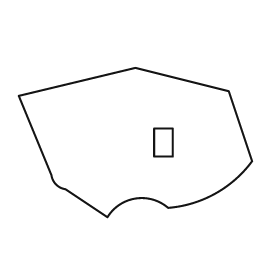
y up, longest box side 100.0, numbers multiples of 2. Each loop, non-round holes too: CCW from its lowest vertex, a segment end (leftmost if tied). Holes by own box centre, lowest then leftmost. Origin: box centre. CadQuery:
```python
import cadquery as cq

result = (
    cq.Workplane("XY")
    .moveTo(-12.0, -32.0)
    .threePointArc((0.0, -24.0), (14.0, -28.0))
    .threePointArc((34.0, -22.0), (50.0, -8.0))
    .lineTo(40.0, 22.0)
    .lineTo(0.0, 32.0)
    .lineTo(-50.0, 20.0)
    .lineTo(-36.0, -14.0)
    .threePointArc((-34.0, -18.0), (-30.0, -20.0))
    .close()
    .moveTo(8.0, -6.0)
    .lineTo(16.0, -6.0)
    .lineTo(16.0, 6.0)
    .lineTo(8.0, 6.0)
    .close()
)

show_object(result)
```